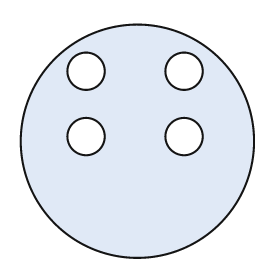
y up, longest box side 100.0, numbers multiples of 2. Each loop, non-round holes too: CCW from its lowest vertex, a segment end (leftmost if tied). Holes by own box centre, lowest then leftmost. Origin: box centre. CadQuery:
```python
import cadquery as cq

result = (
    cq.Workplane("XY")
    .moveTo(0.0, 0.0)
    .circle(50.0)
    .moveTo(-22.0, 2.0)
    .circle(8.0)
    .moveTo(20.0, 2.0)
    .circle(8.0)
    .moveTo(-22.0, 30.0)
    .circle(8.0)
    .moveTo(20.0, 30.0)
    .circle(8.0)
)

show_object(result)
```